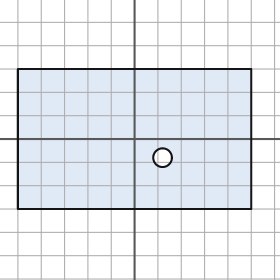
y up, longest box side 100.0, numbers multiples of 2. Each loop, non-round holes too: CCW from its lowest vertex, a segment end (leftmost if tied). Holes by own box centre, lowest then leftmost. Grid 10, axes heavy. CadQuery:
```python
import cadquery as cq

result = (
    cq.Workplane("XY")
    .moveTo(-50.0, -30.0)
    .lineTo(50.0, -30.0)
    .lineTo(50.0, 30.0)
    .lineTo(-50.0, 30.0)
    .close()
    .moveTo(12.0, -8.0)
    .circle(4.0)
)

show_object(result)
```